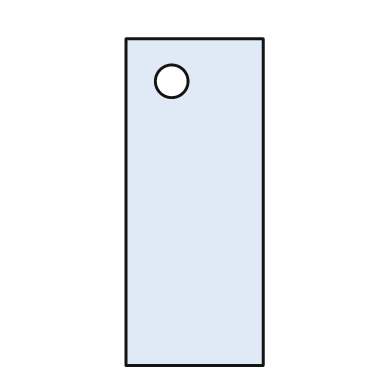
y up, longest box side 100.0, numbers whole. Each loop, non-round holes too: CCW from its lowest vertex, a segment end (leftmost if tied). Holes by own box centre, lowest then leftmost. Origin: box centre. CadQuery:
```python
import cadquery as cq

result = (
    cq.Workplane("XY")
    .moveTo(-21.0, -50.0)
    .lineTo(21.0, -50.0)
    .lineTo(21.0, 50.0)
    .lineTo(-21.0, 50.0)
    .close()
    .moveTo(-7.0, 37.0)
    .circle(5.0)
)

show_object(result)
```